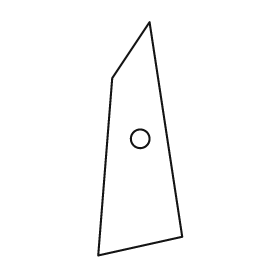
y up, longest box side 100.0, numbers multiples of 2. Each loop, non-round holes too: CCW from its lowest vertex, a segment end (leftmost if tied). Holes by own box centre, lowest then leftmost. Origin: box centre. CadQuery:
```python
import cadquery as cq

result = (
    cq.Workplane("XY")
    .moveTo(-18.0, -50.0)
    .lineTo(18.0, -42.0)
    .lineTo(4.0, 50.0)
    .lineTo(-12.0, 26.0)
    .close()
    .moveTo(0.0, 0.0)
    .circle(4.0)
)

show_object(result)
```